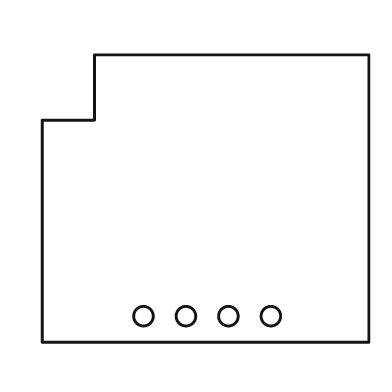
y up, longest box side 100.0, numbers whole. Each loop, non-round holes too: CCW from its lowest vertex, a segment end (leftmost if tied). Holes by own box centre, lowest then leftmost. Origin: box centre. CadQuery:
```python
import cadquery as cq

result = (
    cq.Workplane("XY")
    .moveTo(-50.0, -44.0)
    .lineTo(50.0, -44.0)
    .lineTo(50.0, 44.0)
    .lineTo(-34.0, 44.0)
    .lineTo(-34.0, 24.0)
    .lineTo(-50.0, 24.0)
    .close()
    .moveTo(-19.0, -36.0)
    .circle(3.0)
    .moveTo(-6.0, -36.0)
    .circle(3.0)
    .moveTo(7.0, -36.0)
    .circle(3.0)
    .moveTo(20.0, -36.0)
    .circle(3.0)
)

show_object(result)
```